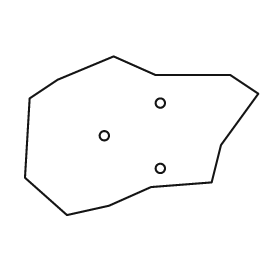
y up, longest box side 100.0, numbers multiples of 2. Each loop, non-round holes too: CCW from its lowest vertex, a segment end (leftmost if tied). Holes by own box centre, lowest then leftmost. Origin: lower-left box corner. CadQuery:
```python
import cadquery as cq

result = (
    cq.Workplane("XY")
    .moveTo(18.0, 0.0)
    .lineTo(36.0, 4.0)
    .lineTo(54.0, 12.0)
    .lineTo(80.0, 14.0)
    .lineTo(84.0, 30.0)
    .lineTo(100.0, 52.0)
    .lineTo(88.0, 60.0)
    .lineTo(56.0, 60.0)
    .lineTo(38.0, 68.0)
    .lineTo(14.0, 58.0)
    .lineTo(2.0, 50.0)
    .lineTo(0.0, 16.0)
    .close()
    .moveTo(58.0, 20.0)
    .circle(2.0)
    .moveTo(34.0, 34.0)
    .circle(2.0)
    .moveTo(58.0, 48.0)
    .circle(2.0)
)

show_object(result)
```